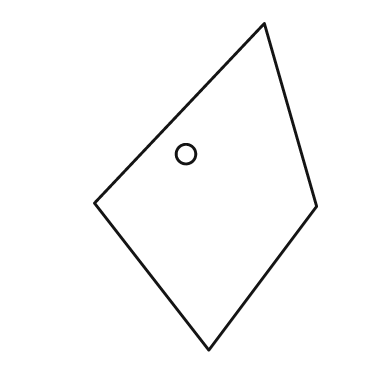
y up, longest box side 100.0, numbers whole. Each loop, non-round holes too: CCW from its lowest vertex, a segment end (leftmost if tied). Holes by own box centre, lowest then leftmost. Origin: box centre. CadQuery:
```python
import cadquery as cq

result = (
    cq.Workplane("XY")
    .moveTo(1.0, -50.0)
    .lineTo(34.0, -6.0)
    .lineTo(18.0, 50.0)
    .lineTo(-34.0, -5.0)
    .close()
    .moveTo(-6.0, 10.0)
    .circle(3.0)
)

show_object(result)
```